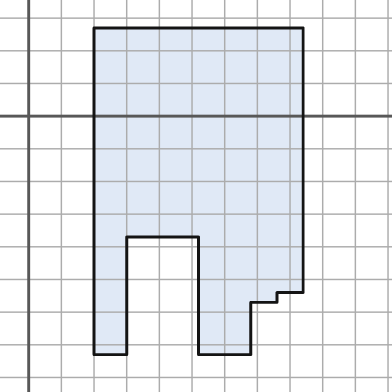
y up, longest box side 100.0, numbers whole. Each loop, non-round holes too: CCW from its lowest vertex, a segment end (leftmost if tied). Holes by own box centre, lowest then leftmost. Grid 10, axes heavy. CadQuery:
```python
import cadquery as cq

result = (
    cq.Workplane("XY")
    .moveTo(20.0, -73.0)
    .lineTo(30.0, -73.0)
    .lineTo(30.0, -37.0)
    .lineTo(52.0, -37.0)
    .lineTo(52.0, -73.0)
    .lineTo(68.0, -73.0)
    .lineTo(68.0, -57.0)
    .lineTo(76.0, -57.0)
    .lineTo(76.0, -54.0)
    .lineTo(84.0, -54.0)
    .lineTo(84.0, 27.0)
    .lineTo(20.0, 27.0)
    .close()
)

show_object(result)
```